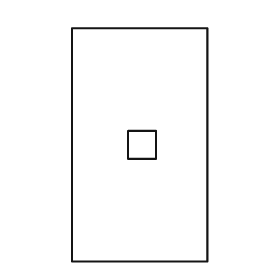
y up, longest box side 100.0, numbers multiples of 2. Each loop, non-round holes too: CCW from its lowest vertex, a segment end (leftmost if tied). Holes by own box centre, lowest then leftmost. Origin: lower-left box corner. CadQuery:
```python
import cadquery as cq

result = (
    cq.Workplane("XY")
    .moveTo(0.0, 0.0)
    .lineTo(58.0, 0.0)
    .lineTo(58.0, 100.0)
    .lineTo(0.0, 100.0)
    .close()
    .moveTo(24.0, 44.0)
    .lineTo(36.0, 44.0)
    .lineTo(36.0, 56.0)
    .lineTo(24.0, 56.0)
    .close()
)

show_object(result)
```